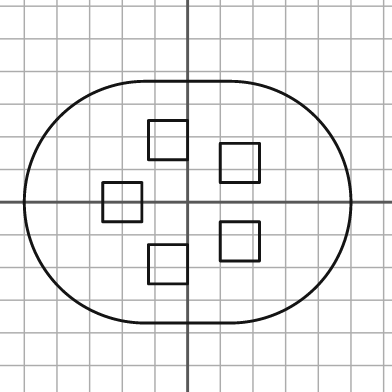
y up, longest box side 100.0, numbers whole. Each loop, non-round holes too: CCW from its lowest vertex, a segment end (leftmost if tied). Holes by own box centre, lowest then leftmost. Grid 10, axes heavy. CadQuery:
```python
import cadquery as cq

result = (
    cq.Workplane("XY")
    .moveTo(-13.0, -37.0)
    .lineTo(13.0, -37.0)
    .threePointArc((50.0, 0.0), (13.0, 37.0))
    .lineTo(-13.0, 37.0)
    .threePointArc((-50.0, 0.0), (-13.0, -37.0))
    .close()
    .moveTo(-12.0, -25.0)
    .lineTo(0.0, -25.0)
    .lineTo(0.0, -13.0)
    .lineTo(-12.0, -13.0)
    .close()
    .moveTo(10.0, -18.0)
    .lineTo(22.0, -18.0)
    .lineTo(22.0, -6.0)
    .lineTo(10.0, -6.0)
    .close()
    .moveTo(-26.0, -6.0)
    .lineTo(-14.0, -6.0)
    .lineTo(-14.0, 6.0)
    .lineTo(-26.0, 6.0)
    .close()
    .moveTo(10.0, 6.0)
    .lineTo(22.0, 6.0)
    .lineTo(22.0, 18.0)
    .lineTo(10.0, 18.0)
    .close()
    .moveTo(-12.0, 13.0)
    .lineTo(0.0, 13.0)
    .lineTo(0.0, 25.0)
    .lineTo(-12.0, 25.0)
    .close()
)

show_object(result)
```